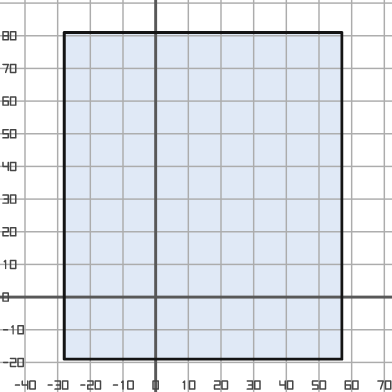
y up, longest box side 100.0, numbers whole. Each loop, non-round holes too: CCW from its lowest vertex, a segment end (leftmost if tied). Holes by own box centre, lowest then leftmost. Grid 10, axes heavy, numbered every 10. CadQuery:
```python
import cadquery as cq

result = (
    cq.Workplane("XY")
    .moveTo(-28.0, -19.0)
    .lineTo(57.0, -19.0)
    .lineTo(57.0, 81.0)
    .lineTo(-28.0, 81.0)
    .close()
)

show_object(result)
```